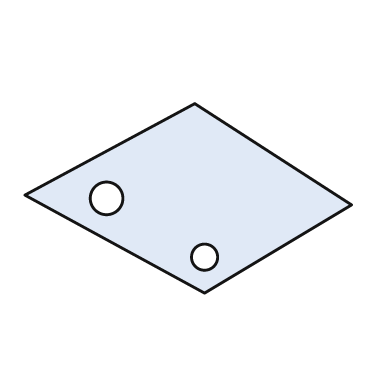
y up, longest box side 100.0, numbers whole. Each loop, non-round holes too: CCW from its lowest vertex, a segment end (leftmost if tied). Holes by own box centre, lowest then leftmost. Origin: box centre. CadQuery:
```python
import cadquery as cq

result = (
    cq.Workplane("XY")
    .moveTo(5.0, -29.0)
    .lineTo(50.0, -2.0)
    .lineTo(2.0, 29.0)
    .lineTo(-50.0, 1.0)
    .close()
    .moveTo(5.0, -18.0)
    .circle(4.0)
    .moveTo(-25.0, 0.0)
    .circle(5.0)
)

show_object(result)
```